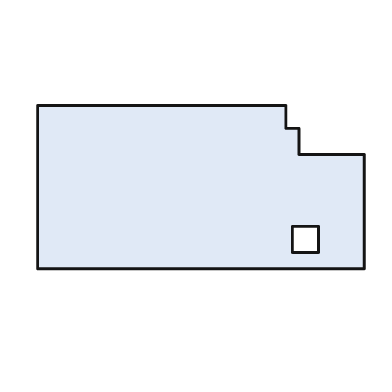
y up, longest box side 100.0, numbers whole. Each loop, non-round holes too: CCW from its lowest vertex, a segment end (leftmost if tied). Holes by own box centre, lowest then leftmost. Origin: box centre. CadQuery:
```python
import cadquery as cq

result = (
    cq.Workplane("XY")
    .moveTo(-50.0, -25.0)
    .lineTo(50.0, -25.0)
    .lineTo(50.0, 10.0)
    .lineTo(30.0, 10.0)
    .lineTo(30.0, 18.0)
    .lineTo(26.0, 18.0)
    .lineTo(26.0, 25.0)
    .lineTo(-50.0, 25.0)
    .close()
    .moveTo(28.0, -20.0)
    .lineTo(36.0, -20.0)
    .lineTo(36.0, -12.0)
    .lineTo(28.0, -12.0)
    .close()
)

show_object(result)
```